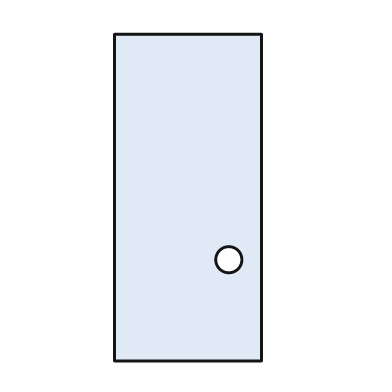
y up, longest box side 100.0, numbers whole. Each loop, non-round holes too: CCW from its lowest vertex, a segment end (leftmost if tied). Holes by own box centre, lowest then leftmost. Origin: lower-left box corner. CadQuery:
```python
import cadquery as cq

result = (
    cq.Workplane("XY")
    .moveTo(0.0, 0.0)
    .lineTo(45.0, 0.0)
    .lineTo(45.0, 100.0)
    .lineTo(0.0, 100.0)
    .close()
    .moveTo(35.0, 31.0)
    .circle(4.0)
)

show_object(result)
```